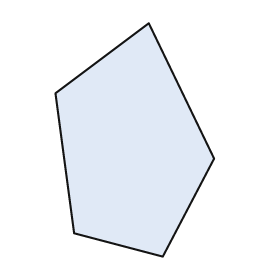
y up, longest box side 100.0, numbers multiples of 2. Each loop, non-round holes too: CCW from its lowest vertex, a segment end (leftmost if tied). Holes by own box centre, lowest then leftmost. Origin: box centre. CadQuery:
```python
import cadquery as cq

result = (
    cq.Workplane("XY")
    .moveTo(12.0, -50.0)
    .lineTo(34.0, -8.0)
    .lineTo(6.0, 50.0)
    .lineTo(-34.0, 20.0)
    .lineTo(-26.0, -40.0)
    .close()
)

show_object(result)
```